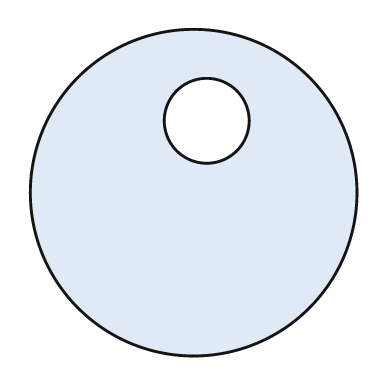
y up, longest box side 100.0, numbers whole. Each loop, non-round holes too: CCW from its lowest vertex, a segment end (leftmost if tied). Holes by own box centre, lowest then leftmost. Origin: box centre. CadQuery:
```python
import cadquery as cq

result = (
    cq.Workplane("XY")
    .moveTo(0.0, 0.0)
    .circle(50.0)
    .moveTo(4.0, 22.0)
    .circle(13.0)
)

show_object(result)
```